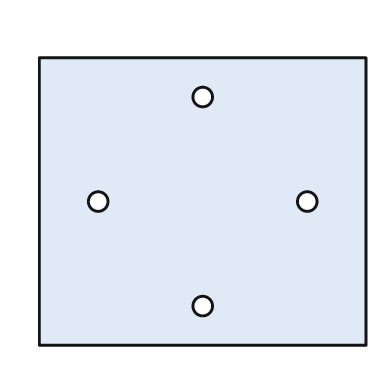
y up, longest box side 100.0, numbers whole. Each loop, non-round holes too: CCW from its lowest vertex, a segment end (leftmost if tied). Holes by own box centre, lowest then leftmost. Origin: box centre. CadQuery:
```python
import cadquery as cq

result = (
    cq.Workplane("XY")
    .moveTo(-50.0, -44.0)
    .lineTo(50.0, -44.0)
    .lineTo(50.0, 44.0)
    .lineTo(-50.0, 44.0)
    .close()
    .moveTo(0.0, -32.0)
    .circle(3.0)
    .moveTo(-32.0, 0.0)
    .circle(3.0)
    .moveTo(32.0, 0.0)
    .circle(3.0)
    .moveTo(0.0, 32.0)
    .circle(3.0)
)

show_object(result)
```